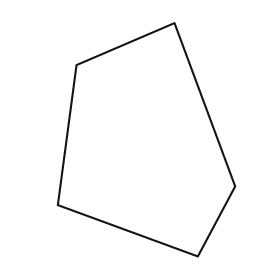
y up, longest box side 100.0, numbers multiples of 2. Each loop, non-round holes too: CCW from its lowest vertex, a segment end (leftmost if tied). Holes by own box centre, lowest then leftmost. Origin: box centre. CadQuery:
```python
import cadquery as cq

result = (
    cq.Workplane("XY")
    .moveTo(22.0, -50.0)
    .lineTo(38.0, -20.0)
    .lineTo(12.0, 50.0)
    .lineTo(-30.0, 32.0)
    .lineTo(-38.0, -28.0)
    .close()
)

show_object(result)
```